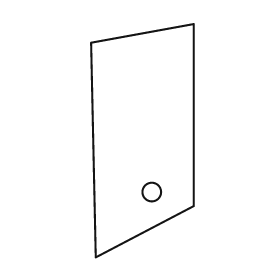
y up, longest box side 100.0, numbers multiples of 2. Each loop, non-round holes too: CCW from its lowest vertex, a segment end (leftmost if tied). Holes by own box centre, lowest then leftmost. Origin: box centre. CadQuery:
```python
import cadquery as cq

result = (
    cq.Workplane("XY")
    .moveTo(-20.0, -50.0)
    .lineTo(22.0, -28.0)
    .lineTo(22.0, 50.0)
    .lineTo(-22.0, 42.0)
    .close()
    .moveTo(4.0, -22.0)
    .circle(4.0)
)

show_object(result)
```